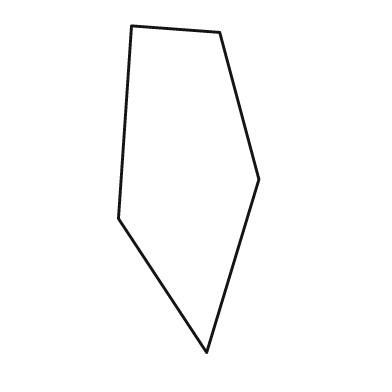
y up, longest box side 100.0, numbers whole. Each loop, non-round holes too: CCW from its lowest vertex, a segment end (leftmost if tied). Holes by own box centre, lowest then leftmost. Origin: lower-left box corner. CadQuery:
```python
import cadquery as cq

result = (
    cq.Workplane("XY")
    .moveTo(27.0, 0.0)
    .lineTo(43.0, 53.0)
    .lineTo(31.0, 98.0)
    .lineTo(4.0, 100.0)
    .lineTo(0.0, 41.0)
    .close()
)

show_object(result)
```